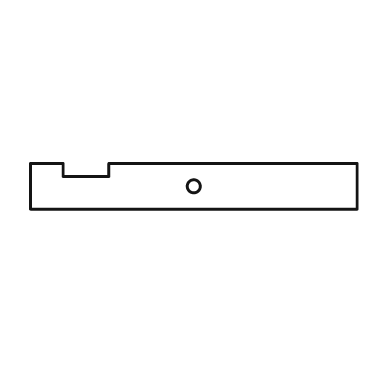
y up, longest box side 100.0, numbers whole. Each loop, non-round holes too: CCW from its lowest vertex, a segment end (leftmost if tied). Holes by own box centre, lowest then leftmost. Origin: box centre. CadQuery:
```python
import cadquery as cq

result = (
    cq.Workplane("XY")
    .moveTo(-50.0, -7.0)
    .lineTo(50.0, -7.0)
    .lineTo(50.0, 7.0)
    .lineTo(-26.0, 7.0)
    .lineTo(-26.0, 3.0)
    .lineTo(-40.0, 3.0)
    .lineTo(-40.0, 7.0)
    .lineTo(-50.0, 7.0)
    .close()
    .moveTo(0.0, 0.0)
    .circle(2.0)
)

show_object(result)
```